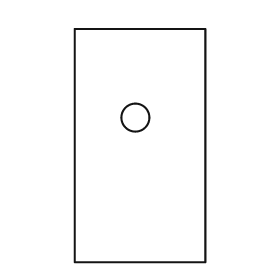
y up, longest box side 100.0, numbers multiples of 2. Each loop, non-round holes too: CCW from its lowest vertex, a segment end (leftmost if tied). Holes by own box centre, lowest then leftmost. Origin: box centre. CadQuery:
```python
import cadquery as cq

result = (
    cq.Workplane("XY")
    .moveTo(-28.0, -50.0)
    .lineTo(28.0, -50.0)
    .lineTo(28.0, 50.0)
    .lineTo(-28.0, 50.0)
    .close()
    .moveTo(-2.0, 12.0)
    .circle(6.0)
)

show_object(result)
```